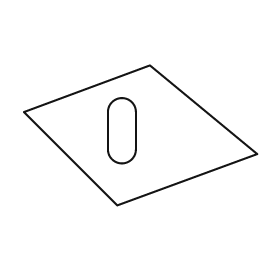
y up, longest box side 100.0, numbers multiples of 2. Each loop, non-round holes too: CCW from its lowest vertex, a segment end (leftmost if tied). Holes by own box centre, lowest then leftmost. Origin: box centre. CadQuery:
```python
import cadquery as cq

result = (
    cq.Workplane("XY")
    .moveTo(-10.0, -30.0)
    .lineTo(50.0, -8.0)
    .lineTo(4.0, 30.0)
    .lineTo(-50.0, 10.0)
    .close()
    .moveTo(-14.0, -6.0)
    .threePointArc((-8.0, -12.0), (-2.0, -6.0))
    .lineTo(-2.0, 10.0)
    .threePointArc((-8.0, 16.0), (-14.0, 10.0))
    .close()
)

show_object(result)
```